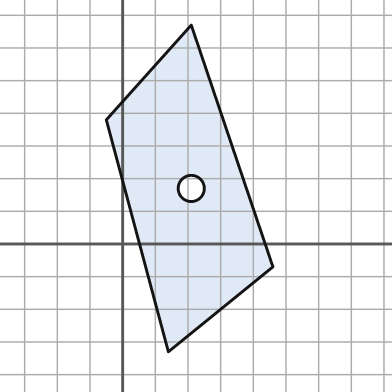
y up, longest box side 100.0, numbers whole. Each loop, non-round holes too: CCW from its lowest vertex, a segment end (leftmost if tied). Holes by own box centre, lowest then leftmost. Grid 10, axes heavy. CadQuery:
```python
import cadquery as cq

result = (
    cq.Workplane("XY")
    .moveTo(14.0, -33.0)
    .lineTo(46.0, -7.0)
    .lineTo(21.0, 67.0)
    .lineTo(-5.0, 38.0)
    .close()
    .moveTo(21.0, 17.0)
    .circle(4.0)
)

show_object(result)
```